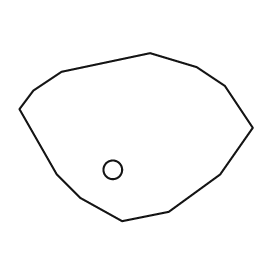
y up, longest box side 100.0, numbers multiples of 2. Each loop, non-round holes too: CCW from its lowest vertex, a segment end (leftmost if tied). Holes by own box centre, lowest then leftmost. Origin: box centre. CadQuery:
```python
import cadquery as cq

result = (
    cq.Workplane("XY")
    .moveTo(-6.0, -36.0)
    .lineTo(14.0, -32.0)
    .lineTo(36.0, -16.0)
    .lineTo(50.0, 4.0)
    .lineTo(38.0, 22.0)
    .lineTo(26.0, 30.0)
    .lineTo(6.0, 36.0)
    .lineTo(-32.0, 28.0)
    .lineTo(-44.0, 20.0)
    .lineTo(-50.0, 12.0)
    .lineTo(-34.0, -16.0)
    .lineTo(-24.0, -26.0)
    .close()
    .moveTo(-10.0, -14.0)
    .circle(4.0)
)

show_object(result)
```